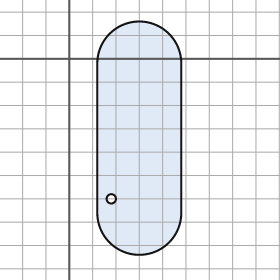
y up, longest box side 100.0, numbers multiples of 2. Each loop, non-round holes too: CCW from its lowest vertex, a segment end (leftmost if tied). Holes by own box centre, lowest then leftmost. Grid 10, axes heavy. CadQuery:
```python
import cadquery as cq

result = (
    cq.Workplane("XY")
    .moveTo(12.0, -66.0)
    .threePointArc((30.0, -84.0), (48.0, -66.0))
    .lineTo(48.0, -2.0)
    .threePointArc((30.0, 16.0), (12.0, -2.0))
    .close()
    .moveTo(18.0, -60.0)
    .circle(2.0)
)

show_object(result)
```